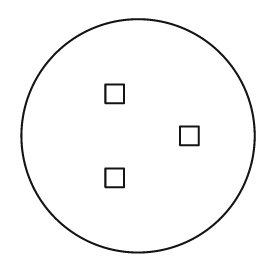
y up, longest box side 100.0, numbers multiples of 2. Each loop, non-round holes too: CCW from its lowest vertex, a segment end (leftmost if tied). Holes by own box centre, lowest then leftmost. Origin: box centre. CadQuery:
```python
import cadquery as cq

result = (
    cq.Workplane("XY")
    .moveTo(0.0, 0.0)
    .circle(50.0)
    .moveTo(-14.0, -22.0)
    .lineTo(-6.0, -22.0)
    .lineTo(-6.0, -14.0)
    .lineTo(-14.0, -14.0)
    .close()
    .moveTo(18.0, -4.0)
    .lineTo(26.0, -4.0)
    .lineTo(26.0, 4.0)
    .lineTo(18.0, 4.0)
    .close()
    .moveTo(-14.0, 14.0)
    .lineTo(-6.0, 14.0)
    .lineTo(-6.0, 22.0)
    .lineTo(-14.0, 22.0)
    .close()
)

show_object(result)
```